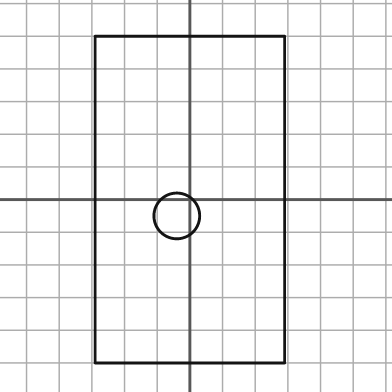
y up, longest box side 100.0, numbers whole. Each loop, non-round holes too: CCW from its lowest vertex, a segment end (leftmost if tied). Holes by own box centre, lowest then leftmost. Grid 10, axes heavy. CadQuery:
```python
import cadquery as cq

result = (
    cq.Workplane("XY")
    .moveTo(-29.0, -50.0)
    .lineTo(29.0, -50.0)
    .lineTo(29.0, 50.0)
    .lineTo(-29.0, 50.0)
    .close()
    .moveTo(-4.0, -5.0)
    .circle(7.0)
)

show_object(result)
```